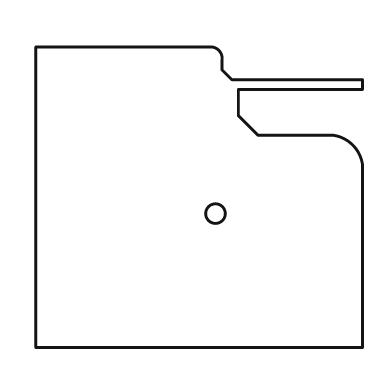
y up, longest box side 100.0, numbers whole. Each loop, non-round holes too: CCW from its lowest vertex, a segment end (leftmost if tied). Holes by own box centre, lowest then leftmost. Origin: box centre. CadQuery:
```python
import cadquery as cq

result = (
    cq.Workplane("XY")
    .moveTo(-50.0, -46.0)
    .lineTo(50.0, -46.0)
    .lineTo(50.0, 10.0)
    .threePointArc((47.0, 16.0), (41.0, 19.0))
    .lineTo(18.0, 19.0)
    .lineTo(12.0, 25.0)
    .lineTo(12.0, 33.0)
    .lineTo(50.0, 33.0)
    .lineTo(50.0, 36.0)
    .lineTo(10.0, 36.0)
    .lineTo(7.0, 39.0)
    .lineTo(7.0, 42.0)
    .threePointArc((6.0, 45.0), (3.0, 46.0))
    .lineTo(-50.0, 46.0)
    .close()
    .moveTo(5.0, -5.0)
    .circle(3.0)
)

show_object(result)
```